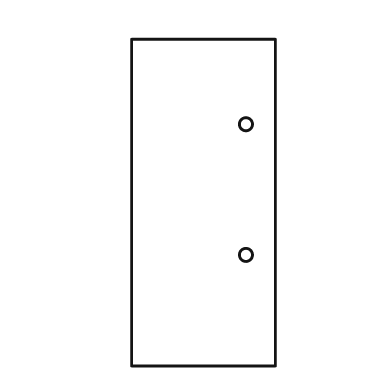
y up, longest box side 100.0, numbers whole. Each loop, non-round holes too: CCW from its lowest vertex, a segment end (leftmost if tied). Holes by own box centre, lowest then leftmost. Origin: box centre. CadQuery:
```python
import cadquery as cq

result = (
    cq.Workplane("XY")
    .moveTo(-22.0, -50.0)
    .lineTo(22.0, -50.0)
    .lineTo(22.0, 50.0)
    .lineTo(-22.0, 50.0)
    .close()
    .moveTo(13.0, -16.0)
    .circle(2.0)
    .moveTo(13.0, 24.0)
    .circle(2.0)
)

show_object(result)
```